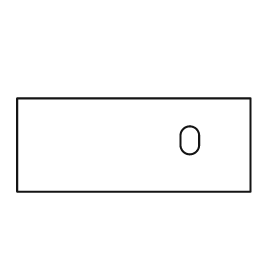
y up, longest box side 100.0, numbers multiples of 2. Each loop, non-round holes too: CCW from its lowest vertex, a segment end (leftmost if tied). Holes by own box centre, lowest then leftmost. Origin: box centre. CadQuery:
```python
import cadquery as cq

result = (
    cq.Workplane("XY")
    .moveTo(-50.0, -20.0)
    .lineTo(50.0, -20.0)
    .lineTo(50.0, 20.0)
    .lineTo(-50.0, 20.0)
    .close()
    .moveTo(20.0, 0.0)
    .threePointArc((24.0, -4.0), (28.0, 0.0))
    .lineTo(28.0, 4.0)
    .threePointArc((24.0, 8.0), (20.0, 4.0))
    .close()
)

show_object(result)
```